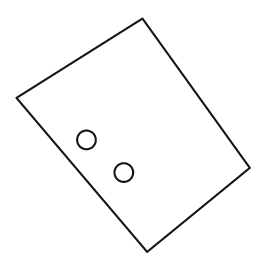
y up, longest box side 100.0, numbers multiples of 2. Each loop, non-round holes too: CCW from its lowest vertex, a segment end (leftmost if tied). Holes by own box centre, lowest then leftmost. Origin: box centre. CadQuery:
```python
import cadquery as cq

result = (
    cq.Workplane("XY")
    .moveTo(6.0, -50.0)
    .lineTo(50.0, -14.0)
    .lineTo(4.0, 50.0)
    .lineTo(-50.0, 16.0)
    .close()
    .moveTo(-4.0, -16.0)
    .circle(4.0)
    .moveTo(-20.0, -2.0)
    .circle(4.0)
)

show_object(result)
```